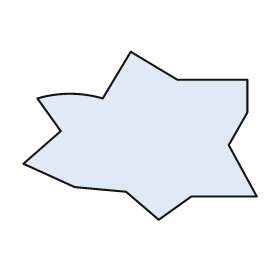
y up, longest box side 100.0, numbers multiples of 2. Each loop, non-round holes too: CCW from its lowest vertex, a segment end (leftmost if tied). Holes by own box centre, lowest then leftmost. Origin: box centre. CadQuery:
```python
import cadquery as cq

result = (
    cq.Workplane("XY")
    .moveTo(8.0, -36.0)
    .lineTo(22.0, -26.0)
    .lineTo(50.0, -26.0)
    .lineTo(38.0, -4.0)
    .lineTo(46.0, 10.0)
    .lineTo(46.0, 24.0)
    .lineTo(16.0, 24.0)
    .lineTo(-4.0, 36.0)
    .lineTo(-16.0, 16.0)
    .threePointArc((-30.0, 18.0), (-44.0, 16.0))
    .lineTo(-34.0, 2.0)
    .lineTo(-50.0, -12.0)
    .lineTo(-28.0, -22.0)
    .lineTo(-6.0, -24.0)
    .close()
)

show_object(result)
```